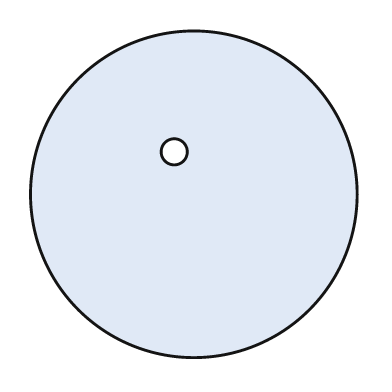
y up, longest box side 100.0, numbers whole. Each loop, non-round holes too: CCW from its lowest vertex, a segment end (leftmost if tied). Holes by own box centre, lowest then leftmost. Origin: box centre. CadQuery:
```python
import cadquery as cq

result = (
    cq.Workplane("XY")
    .moveTo(0.0, 0.0)
    .circle(50.0)
    .moveTo(-6.0, 13.0)
    .circle(4.0)
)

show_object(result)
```